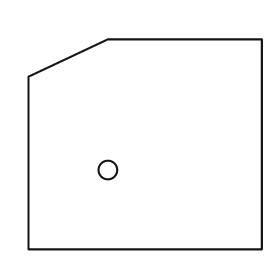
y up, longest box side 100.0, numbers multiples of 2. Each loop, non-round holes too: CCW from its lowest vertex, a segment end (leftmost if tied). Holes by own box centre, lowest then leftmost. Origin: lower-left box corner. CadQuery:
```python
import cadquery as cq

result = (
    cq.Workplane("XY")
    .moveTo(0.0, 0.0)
    .lineTo(100.0, 0.0)
    .lineTo(100.0, 90.0)
    .lineTo(34.0, 90.0)
    .lineTo(0.0, 74.0)
    .close()
    .moveTo(34.0, 34.0)
    .circle(4.0)
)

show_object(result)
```